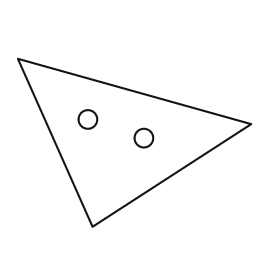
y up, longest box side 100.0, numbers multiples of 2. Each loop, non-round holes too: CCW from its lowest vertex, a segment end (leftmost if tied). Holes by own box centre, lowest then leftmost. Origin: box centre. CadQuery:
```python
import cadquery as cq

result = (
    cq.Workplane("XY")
    .moveTo(-18.0, -36.0)
    .lineTo(50.0, 8.0)
    .lineTo(-50.0, 36.0)
    .close()
    .moveTo(4.0, 2.0)
    .circle(4.0)
    .moveTo(-20.0, 10.0)
    .circle(4.0)
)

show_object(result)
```